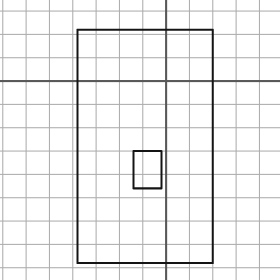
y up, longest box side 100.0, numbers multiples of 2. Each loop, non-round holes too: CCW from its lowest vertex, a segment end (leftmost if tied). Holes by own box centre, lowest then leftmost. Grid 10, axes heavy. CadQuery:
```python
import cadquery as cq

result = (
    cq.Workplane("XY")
    .moveTo(-38.0, -78.0)
    .lineTo(20.0, -78.0)
    .lineTo(20.0, 22.0)
    .lineTo(-38.0, 22.0)
    .close()
    .moveTo(-14.0, -46.0)
    .lineTo(-2.0, -46.0)
    .lineTo(-2.0, -30.0)
    .lineTo(-14.0, -30.0)
    .close()
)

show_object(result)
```